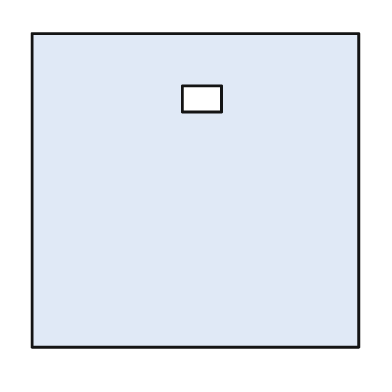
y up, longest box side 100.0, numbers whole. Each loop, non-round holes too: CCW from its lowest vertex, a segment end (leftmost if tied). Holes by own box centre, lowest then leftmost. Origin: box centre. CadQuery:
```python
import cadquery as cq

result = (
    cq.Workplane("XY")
    .moveTo(-50.0, -48.0)
    .lineTo(50.0, -48.0)
    .lineTo(50.0, 48.0)
    .lineTo(-50.0, 48.0)
    .close()
    .moveTo(-4.0, 24.0)
    .lineTo(8.0, 24.0)
    .lineTo(8.0, 32.0)
    .lineTo(-4.0, 32.0)
    .close()
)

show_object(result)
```